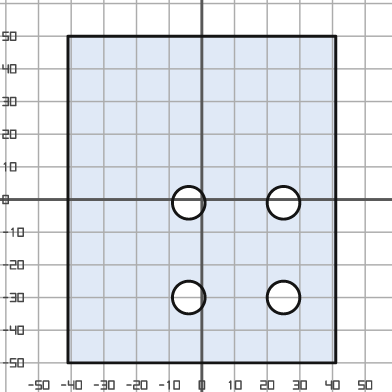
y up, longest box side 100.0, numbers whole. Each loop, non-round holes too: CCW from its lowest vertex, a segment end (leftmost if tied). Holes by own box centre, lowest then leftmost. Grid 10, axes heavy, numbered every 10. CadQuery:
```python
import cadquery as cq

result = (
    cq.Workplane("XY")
    .moveTo(-41.0, -50.0)
    .lineTo(41.0, -50.0)
    .lineTo(41.0, 50.0)
    .lineTo(-41.0, 50.0)
    .close()
    .moveTo(-4.0, -30.0)
    .circle(5.0)
    .moveTo(25.0, -30.0)
    .circle(5.0)
    .moveTo(-4.0, -1.0)
    .circle(5.0)
    .moveTo(25.0, -1.0)
    .circle(5.0)
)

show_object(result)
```